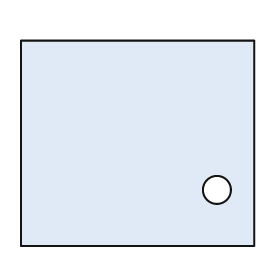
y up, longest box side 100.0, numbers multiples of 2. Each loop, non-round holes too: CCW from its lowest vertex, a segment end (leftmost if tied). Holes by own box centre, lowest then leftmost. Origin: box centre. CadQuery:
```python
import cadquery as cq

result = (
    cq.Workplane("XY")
    .moveTo(-50.0, -44.0)
    .lineTo(50.0, -44.0)
    .lineTo(50.0, 44.0)
    .lineTo(-50.0, 44.0)
    .close()
    .moveTo(34.0, -20.0)
    .circle(6.0)
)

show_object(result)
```